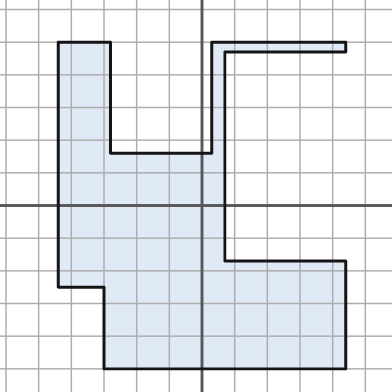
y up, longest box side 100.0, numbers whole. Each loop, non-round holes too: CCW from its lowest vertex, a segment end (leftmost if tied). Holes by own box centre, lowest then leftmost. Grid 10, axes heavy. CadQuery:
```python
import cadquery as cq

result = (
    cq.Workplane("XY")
    .moveTo(-30.0, -50.0)
    .lineTo(44.0, -50.0)
    .lineTo(44.0, -17.0)
    .lineTo(7.0, -17.0)
    .lineTo(7.0, 47.0)
    .lineTo(44.0, 47.0)
    .lineTo(44.0, 50.0)
    .lineTo(3.0, 50.0)
    .lineTo(3.0, 16.0)
    .lineTo(-28.0, 16.0)
    .lineTo(-28.0, 50.0)
    .lineTo(-44.0, 50.0)
    .lineTo(-44.0, -25.0)
    .lineTo(-30.0, -25.0)
    .close()
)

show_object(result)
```